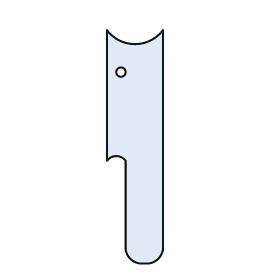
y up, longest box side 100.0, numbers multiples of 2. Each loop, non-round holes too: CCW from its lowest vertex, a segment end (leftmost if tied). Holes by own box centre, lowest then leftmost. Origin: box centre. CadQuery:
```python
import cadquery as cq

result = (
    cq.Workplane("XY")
    .moveTo(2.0, -50.0)
    .lineTo(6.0, -50.0)
    .threePointArc((10.0, -48.0), (12.0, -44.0))
    .lineTo(12.0, 50.0)
    .threePointArc((0.0, 44.0), (-12.0, 50.0))
    .lineTo(-12.0, -6.0)
    .threePointArc((-8.0, -4.0), (-4.0, -6.0))
    .lineTo(-4.0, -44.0)
    .threePointArc((-2.0, -48.0), (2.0, -50.0))
    .close()
    .moveTo(-6.0, 32.0)
    .circle(2.0)
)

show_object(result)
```